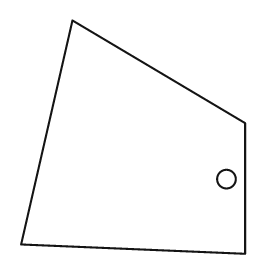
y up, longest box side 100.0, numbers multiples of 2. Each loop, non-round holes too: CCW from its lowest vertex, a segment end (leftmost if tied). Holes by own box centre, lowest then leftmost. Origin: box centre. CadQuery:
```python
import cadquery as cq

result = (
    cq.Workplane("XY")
    .moveTo(48.0, -50.0)
    .lineTo(48.0, 6.0)
    .lineTo(-26.0, 50.0)
    .lineTo(-48.0, -46.0)
    .close()
    .moveTo(40.0, -18.0)
    .circle(4.0)
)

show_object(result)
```